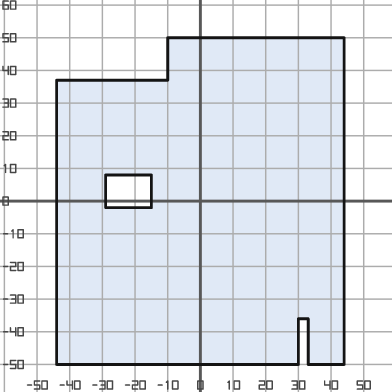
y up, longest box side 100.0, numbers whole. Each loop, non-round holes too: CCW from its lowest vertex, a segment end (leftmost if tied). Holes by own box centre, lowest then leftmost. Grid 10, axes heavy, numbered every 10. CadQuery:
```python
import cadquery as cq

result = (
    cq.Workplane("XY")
    .moveTo(-44.0, -50.0)
    .lineTo(30.0, -50.0)
    .lineTo(30.0, -36.0)
    .lineTo(33.0, -36.0)
    .lineTo(33.0, -50.0)
    .lineTo(44.0, -50.0)
    .lineTo(44.0, 50.0)
    .lineTo(-10.0, 50.0)
    .lineTo(-10.0, 37.0)
    .lineTo(-44.0, 37.0)
    .close()
    .moveTo(-29.0, -2.0)
    .lineTo(-15.0, -2.0)
    .lineTo(-15.0, 8.0)
    .lineTo(-29.0, 8.0)
    .close()
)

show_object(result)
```